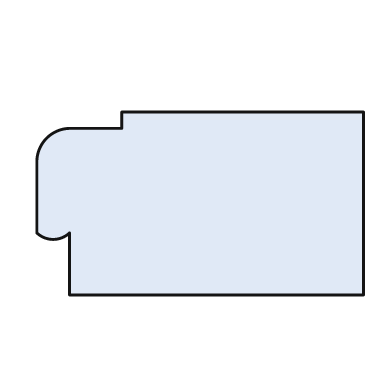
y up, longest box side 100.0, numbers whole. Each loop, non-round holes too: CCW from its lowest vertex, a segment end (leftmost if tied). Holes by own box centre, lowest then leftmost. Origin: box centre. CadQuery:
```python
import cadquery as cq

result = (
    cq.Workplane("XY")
    .moveTo(-40.0, -28.0)
    .lineTo(50.0, -28.0)
    .lineTo(50.0, 28.0)
    .lineTo(-24.0, 28.0)
    .lineTo(-24.0, 23.0)
    .lineTo(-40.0, 23.0)
    .threePointArc((-47.0, 20.0), (-50.0, 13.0))
    .lineTo(-50.0, -9.0)
    .threePointArc((-45.0, -11.0), (-40.0, -9.0))
    .close()
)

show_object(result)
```